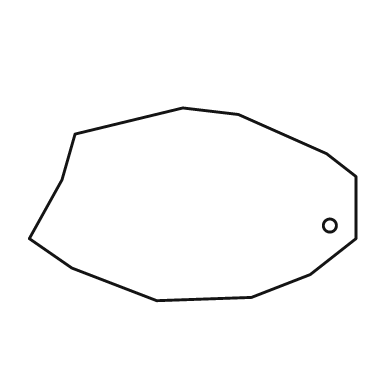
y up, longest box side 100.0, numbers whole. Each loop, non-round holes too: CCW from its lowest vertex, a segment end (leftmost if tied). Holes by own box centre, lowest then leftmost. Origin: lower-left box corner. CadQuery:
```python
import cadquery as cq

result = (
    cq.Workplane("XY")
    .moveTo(39.0, 0.0)
    .lineTo(68.0, 1.0)
    .lineTo(86.0, 8.0)
    .lineTo(100.0, 19.0)
    .lineTo(100.0, 38.0)
    .lineTo(91.0, 45.0)
    .lineTo(64.0, 57.0)
    .lineTo(47.0, 59.0)
    .lineTo(14.0, 51.0)
    .lineTo(10.0, 37.0)
    .lineTo(0.0, 19.0)
    .lineTo(13.0, 10.0)
    .close()
    .moveTo(92.0, 23.0)
    .circle(2.0)
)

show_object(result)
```